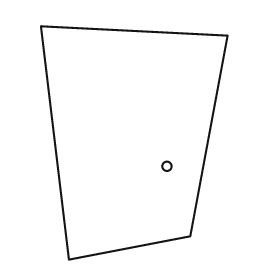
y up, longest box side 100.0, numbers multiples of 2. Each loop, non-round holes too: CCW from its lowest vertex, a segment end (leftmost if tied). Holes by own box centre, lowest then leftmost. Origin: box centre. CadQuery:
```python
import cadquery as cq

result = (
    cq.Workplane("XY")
    .moveTo(-28.0, -50.0)
    .lineTo(24.0, -40.0)
    .lineTo(40.0, 46.0)
    .lineTo(-40.0, 50.0)
    .close()
    .moveTo(14.0, -10.0)
    .circle(2.0)
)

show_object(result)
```